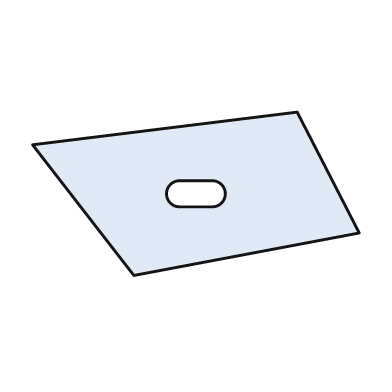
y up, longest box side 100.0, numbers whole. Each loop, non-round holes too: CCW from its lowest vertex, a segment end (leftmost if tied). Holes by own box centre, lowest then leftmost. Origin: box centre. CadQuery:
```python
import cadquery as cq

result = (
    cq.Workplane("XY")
    .moveTo(-19.0, -25.0)
    .lineTo(50.0, -12.0)
    .lineTo(31.0, 25.0)
    .lineTo(-50.0, 15.0)
    .close()
    .moveTo(-5.0, -4.0)
    .lineTo(5.0, -4.0)
    .threePointArc((9.0, 0.0), (5.0, 4.0))
    .lineTo(-5.0, 4.0)
    .threePointArc((-9.0, 0.0), (-5.0, -4.0))
    .close()
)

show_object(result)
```